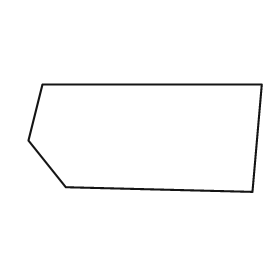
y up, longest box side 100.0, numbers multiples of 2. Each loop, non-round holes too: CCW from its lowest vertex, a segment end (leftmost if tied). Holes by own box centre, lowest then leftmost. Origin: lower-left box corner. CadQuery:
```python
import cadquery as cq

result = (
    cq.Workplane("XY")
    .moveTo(96.0, 0.0)
    .lineTo(100.0, 46.0)
    .lineTo(6.0, 46.0)
    .lineTo(0.0, 22.0)
    .lineTo(16.0, 2.0)
    .close()
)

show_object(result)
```